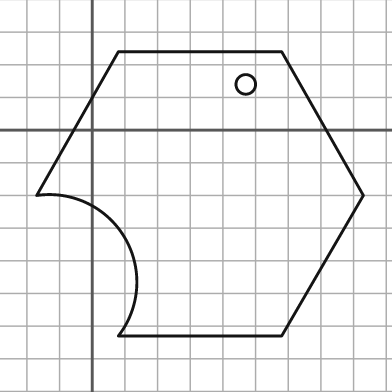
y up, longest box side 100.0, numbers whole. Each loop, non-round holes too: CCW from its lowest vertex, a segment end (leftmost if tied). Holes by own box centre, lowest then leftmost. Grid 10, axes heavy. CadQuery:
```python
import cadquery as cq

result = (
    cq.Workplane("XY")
    .moveTo(8.0, -63.0)
    .lineTo(58.0, -63.0)
    .lineTo(83.0, -20.0)
    .lineTo(58.0, 24.0)
    .lineTo(8.0, 24.0)
    .lineTo(-17.0, -20.0)
    .threePointArc((10.0, -33.0), (8.0, -63.0))
    .close()
    .moveTo(47.0, 14.0)
    .circle(3.0)
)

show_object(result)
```